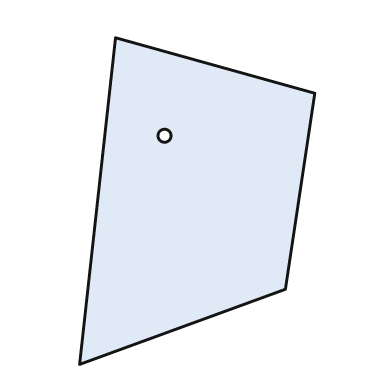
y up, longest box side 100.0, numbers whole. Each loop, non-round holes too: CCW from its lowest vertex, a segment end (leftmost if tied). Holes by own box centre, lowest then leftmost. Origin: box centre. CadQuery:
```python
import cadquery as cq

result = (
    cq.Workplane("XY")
    .moveTo(-36.0, -50.0)
    .lineTo(27.0, -27.0)
    .lineTo(36.0, 33.0)
    .lineTo(-25.0, 50.0)
    .close()
    .moveTo(-10.0, 20.0)
    .circle(2.0)
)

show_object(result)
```